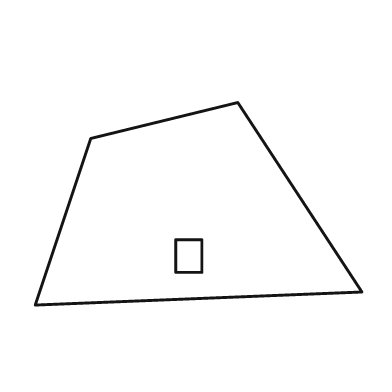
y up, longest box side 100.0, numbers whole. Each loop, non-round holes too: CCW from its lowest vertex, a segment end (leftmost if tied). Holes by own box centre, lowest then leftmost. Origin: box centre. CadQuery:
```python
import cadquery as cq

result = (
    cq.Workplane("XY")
    .moveTo(-50.0, -31.0)
    .lineTo(50.0, -27.0)
    .lineTo(12.0, 31.0)
    .lineTo(-33.0, 20.0)
    .close()
    .moveTo(-7.0, -21.0)
    .lineTo(1.0, -21.0)
    .lineTo(1.0, -11.0)
    .lineTo(-7.0, -11.0)
    .close()
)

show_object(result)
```